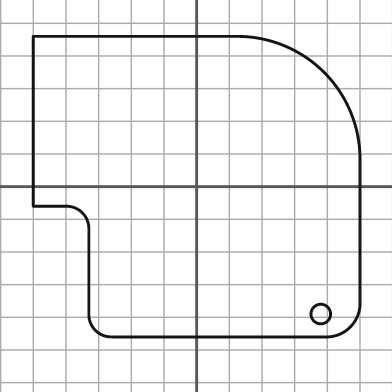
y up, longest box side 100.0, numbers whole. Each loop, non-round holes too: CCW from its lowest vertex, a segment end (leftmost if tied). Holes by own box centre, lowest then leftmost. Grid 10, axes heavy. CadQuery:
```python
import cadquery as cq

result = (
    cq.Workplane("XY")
    .moveTo(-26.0, -46.0)
    .lineTo(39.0, -46.0)
    .threePointArc((47.0, -43.0), (50.0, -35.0))
    .lineTo(50.0, 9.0)
    .threePointArc((39.0, 35.0), (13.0, 46.0))
    .lineTo(-50.0, 46.0)
    .lineTo(-50.0, -6.0)
    .lineTo(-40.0, -6.0)
    .threePointArc((-35.0, -8.0), (-33.0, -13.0))
    .lineTo(-33.0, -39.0)
    .threePointArc((-31.0, -44.0), (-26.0, -46.0))
    .close()
    .moveTo(38.0, -39.0)
    .circle(3.0)
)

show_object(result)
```